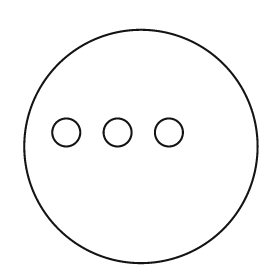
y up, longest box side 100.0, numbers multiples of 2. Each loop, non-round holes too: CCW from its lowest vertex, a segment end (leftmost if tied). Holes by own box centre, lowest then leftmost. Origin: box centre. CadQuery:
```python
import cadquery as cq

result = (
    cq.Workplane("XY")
    .moveTo(0.0, 0.0)
    .circle(50.0)
    .moveTo(-32.0, 6.0)
    .circle(6.0)
    .moveTo(-10.0, 6.0)
    .circle(6.0)
    .moveTo(12.0, 6.0)
    .circle(6.0)
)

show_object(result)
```